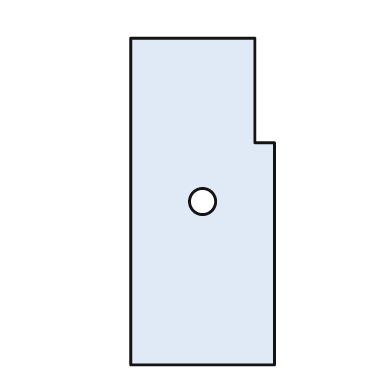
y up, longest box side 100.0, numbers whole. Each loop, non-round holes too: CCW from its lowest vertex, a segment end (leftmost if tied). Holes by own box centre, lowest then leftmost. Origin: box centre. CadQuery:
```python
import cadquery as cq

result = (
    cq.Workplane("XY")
    .moveTo(-22.0, -50.0)
    .lineTo(22.0, -50.0)
    .lineTo(22.0, 18.0)
    .lineTo(16.0, 18.0)
    .lineTo(16.0, 50.0)
    .lineTo(-22.0, 50.0)
    .close()
    .moveTo(0.0, 0.0)
    .circle(4.0)
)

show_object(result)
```